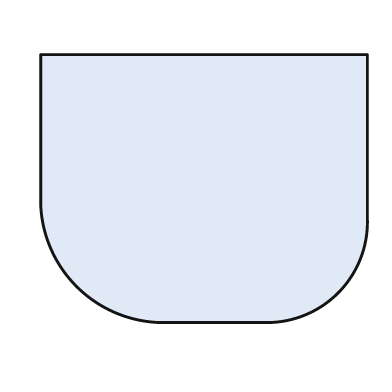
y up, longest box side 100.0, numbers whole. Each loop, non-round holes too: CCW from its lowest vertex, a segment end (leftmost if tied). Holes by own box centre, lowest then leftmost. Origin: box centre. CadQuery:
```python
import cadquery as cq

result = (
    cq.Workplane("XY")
    .moveTo(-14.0, -41.0)
    .lineTo(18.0, -41.0)
    .threePointArc((41.0, -32.0), (50.0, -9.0))
    .lineTo(50.0, 41.0)
    .lineTo(-50.0, 41.0)
    .lineTo(-50.0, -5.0)
    .threePointArc((-39.0, -30.0), (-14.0, -41.0))
    .close()
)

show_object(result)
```